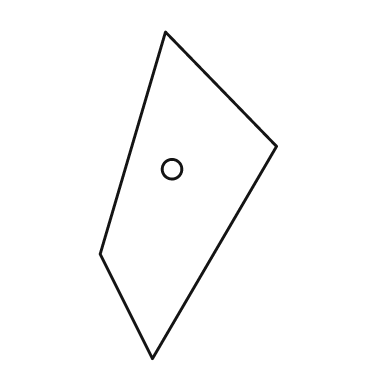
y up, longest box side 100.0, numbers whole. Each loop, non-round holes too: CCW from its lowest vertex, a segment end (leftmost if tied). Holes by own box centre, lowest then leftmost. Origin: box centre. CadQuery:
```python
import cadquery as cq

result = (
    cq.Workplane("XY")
    .moveTo(-11.0, -50.0)
    .lineTo(27.0, 15.0)
    .lineTo(-7.0, 50.0)
    .lineTo(-27.0, -18.0)
    .close()
    .moveTo(-5.0, 8.0)
    .circle(3.0)
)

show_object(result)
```